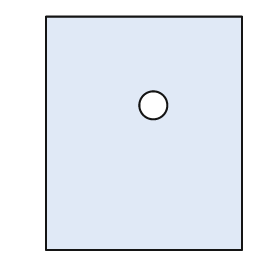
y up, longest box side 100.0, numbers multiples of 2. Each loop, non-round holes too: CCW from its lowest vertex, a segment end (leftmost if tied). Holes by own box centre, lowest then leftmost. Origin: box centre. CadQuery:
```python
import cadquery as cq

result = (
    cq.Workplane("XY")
    .moveTo(-42.0, -50.0)
    .lineTo(42.0, -50.0)
    .lineTo(42.0, 50.0)
    .lineTo(-42.0, 50.0)
    .close()
    .moveTo(4.0, 12.0)
    .circle(6.0)
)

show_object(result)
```